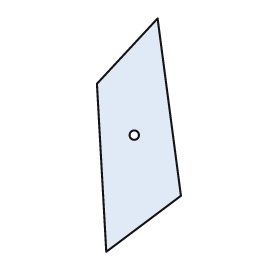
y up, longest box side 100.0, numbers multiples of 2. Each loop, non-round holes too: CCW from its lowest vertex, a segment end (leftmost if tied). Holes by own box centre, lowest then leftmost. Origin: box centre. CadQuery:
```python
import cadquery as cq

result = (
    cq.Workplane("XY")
    .moveTo(-14.0, -50.0)
    .lineTo(18.0, -26.0)
    .lineTo(8.0, 50.0)
    .lineTo(-18.0, 22.0)
    .close()
    .moveTo(-2.0, 0.0)
    .circle(2.0)
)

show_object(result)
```